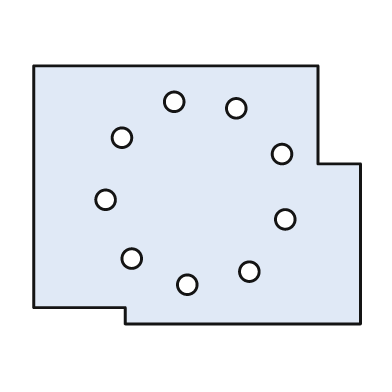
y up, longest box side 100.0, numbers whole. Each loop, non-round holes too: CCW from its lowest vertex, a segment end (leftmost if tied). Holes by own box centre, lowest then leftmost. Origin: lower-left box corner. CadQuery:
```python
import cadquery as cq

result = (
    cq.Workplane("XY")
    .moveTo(28.0, 0.0)
    .lineTo(100.0, 0.0)
    .lineTo(100.0, 49.0)
    .lineTo(87.0, 49.0)
    .lineTo(87.0, 79.0)
    .lineTo(0.0, 79.0)
    .lineTo(0.0, 5.0)
    .lineTo(28.0, 5.0)
    .close()
    .moveTo(47.0, 12.0)
    .circle(3.0)
    .moveTo(66.0, 16.0)
    .circle(3.0)
    .moveTo(30.0, 20.0)
    .circle(3.0)
    .moveTo(77.0, 32.0)
    .circle(3.0)
    .moveTo(22.0, 38.0)
    .circle(3.0)
    .moveTo(76.0, 52.0)
    .circle(3.0)
    .moveTo(27.0, 57.0)
    .circle(3.0)
    .moveTo(62.0, 66.0)
    .circle(3.0)
    .moveTo(43.0, 68.0)
    .circle(3.0)
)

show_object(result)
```